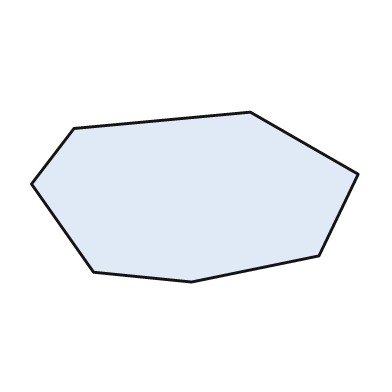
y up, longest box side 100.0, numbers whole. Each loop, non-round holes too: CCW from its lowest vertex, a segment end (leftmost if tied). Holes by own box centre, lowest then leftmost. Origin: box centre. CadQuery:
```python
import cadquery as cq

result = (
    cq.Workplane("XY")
    .moveTo(-1.0, -26.0)
    .lineTo(38.0, -18.0)
    .lineTo(50.0, 7.0)
    .lineTo(17.0, 26.0)
    .lineTo(-37.0, 21.0)
    .lineTo(-50.0, 4.0)
    .lineTo(-31.0, -23.0)
    .close()
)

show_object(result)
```